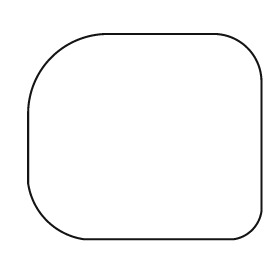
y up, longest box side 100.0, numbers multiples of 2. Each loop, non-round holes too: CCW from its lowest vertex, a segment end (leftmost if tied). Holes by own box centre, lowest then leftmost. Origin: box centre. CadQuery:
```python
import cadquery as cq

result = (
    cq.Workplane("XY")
    .moveTo(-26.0, -44.0)
    .lineTo(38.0, -44.0)
    .threePointArc((46.0, -40.0), (50.0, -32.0))
    .lineTo(50.0, 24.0)
    .threePointArc((44.0, 38.0), (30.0, 44.0))
    .lineTo(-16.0, 44.0)
    .threePointArc((-40.0, 34.0), (-50.0, 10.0))
    .lineTo(-50.0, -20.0)
    .threePointArc((-42.0, -36.0), (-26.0, -44.0))
    .close()
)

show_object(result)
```